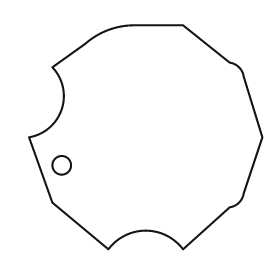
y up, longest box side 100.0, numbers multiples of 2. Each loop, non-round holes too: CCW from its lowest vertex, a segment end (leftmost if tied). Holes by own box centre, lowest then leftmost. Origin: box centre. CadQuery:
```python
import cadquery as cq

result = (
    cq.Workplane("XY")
    .moveTo(-16.0, -48.0)
    .threePointArc((0.0, -40.0), (16.0, -48.0))
    .lineTo(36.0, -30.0)
    .threePointArc((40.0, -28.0), (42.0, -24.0))
    .lineTo(50.0, 0.0)
    .lineTo(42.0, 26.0)
    .threePointArc((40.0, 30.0), (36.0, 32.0))
    .lineTo(16.0, 48.0)
    .lineTo(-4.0, 48.0)
    .threePointArc((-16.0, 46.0), (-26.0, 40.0))
    .lineTo(-40.0, 30.0)
    .threePointArc((-36.0, 12.0), (-50.0, 0.0))
    .lineTo(-40.0, -28.0)
    .close()
    .moveTo(-36.0, -12.0)
    .circle(4.0)
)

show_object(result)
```